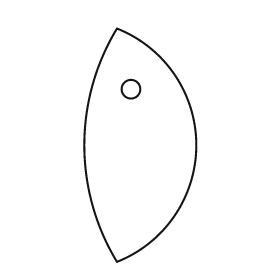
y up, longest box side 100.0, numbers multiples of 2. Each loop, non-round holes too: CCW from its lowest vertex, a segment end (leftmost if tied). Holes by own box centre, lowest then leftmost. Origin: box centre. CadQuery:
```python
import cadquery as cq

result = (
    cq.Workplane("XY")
    .moveTo(-10.0, -50.0)
    .threePointArc((24.0, 0.0), (-10.0, 50.0))
    .threePointArc((-24.0, 0.0), (-10.0, -50.0))
    .close()
    .moveTo(-4.0, 24.0)
    .circle(4.0)
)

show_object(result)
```